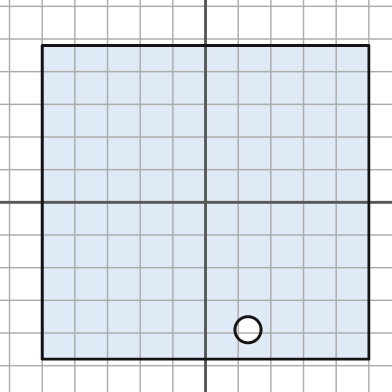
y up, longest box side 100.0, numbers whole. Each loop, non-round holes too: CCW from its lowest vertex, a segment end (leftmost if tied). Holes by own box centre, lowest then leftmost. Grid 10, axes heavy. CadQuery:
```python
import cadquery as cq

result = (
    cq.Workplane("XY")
    .moveTo(-50.0, -48.0)
    .lineTo(50.0, -48.0)
    .lineTo(50.0, 48.0)
    .lineTo(-50.0, 48.0)
    .close()
    .moveTo(13.0, -39.0)
    .circle(4.0)
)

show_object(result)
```